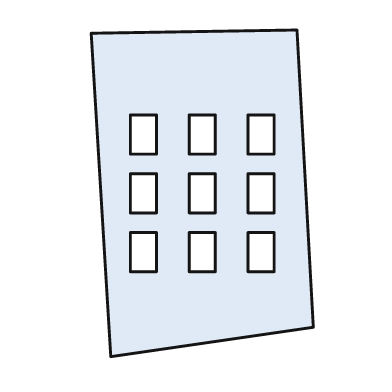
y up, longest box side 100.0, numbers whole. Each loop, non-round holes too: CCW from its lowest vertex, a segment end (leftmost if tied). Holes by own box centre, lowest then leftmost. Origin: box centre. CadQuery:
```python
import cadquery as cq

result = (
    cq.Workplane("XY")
    .moveTo(-28.0, -50.0)
    .lineTo(34.0, -41.0)
    .lineTo(29.0, 50.0)
    .lineTo(-34.0, 49.0)
    .close()
    .moveTo(-22.0, -24.0)
    .lineTo(-14.0, -24.0)
    .lineTo(-14.0, -12.0)
    .lineTo(-22.0, -12.0)
    .close()
    .moveTo(-4.0, -24.0)
    .lineTo(4.0, -24.0)
    .lineTo(4.0, -12.0)
    .lineTo(-4.0, -12.0)
    .close()
    .moveTo(14.0, -24.0)
    .lineTo(22.0, -24.0)
    .lineTo(22.0, -12.0)
    .lineTo(14.0, -12.0)
    .close()
    .moveTo(-22.0, -6.0)
    .lineTo(-14.0, -6.0)
    .lineTo(-14.0, 6.0)
    .lineTo(-22.0, 6.0)
    .close()
    .moveTo(-4.0, -6.0)
    .lineTo(4.0, -6.0)
    .lineTo(4.0, 6.0)
    .lineTo(-4.0, 6.0)
    .close()
    .moveTo(14.0, -6.0)
    .lineTo(22.0, -6.0)
    .lineTo(22.0, 6.0)
    .lineTo(14.0, 6.0)
    .close()
    .moveTo(-22.0, 12.0)
    .lineTo(-14.0, 12.0)
    .lineTo(-14.0, 24.0)
    .lineTo(-22.0, 24.0)
    .close()
    .moveTo(-4.0, 12.0)
    .lineTo(4.0, 12.0)
    .lineTo(4.0, 24.0)
    .lineTo(-4.0, 24.0)
    .close()
    .moveTo(14.0, 12.0)
    .lineTo(22.0, 12.0)
    .lineTo(22.0, 24.0)
    .lineTo(14.0, 24.0)
    .close()
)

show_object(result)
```